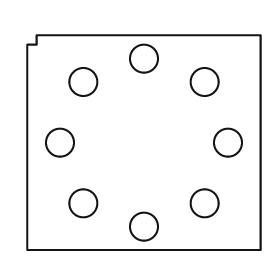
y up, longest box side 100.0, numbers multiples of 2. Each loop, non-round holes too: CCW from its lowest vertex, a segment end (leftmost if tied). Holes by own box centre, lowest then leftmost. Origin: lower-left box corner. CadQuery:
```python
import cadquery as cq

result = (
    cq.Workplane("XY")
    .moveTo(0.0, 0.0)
    .lineTo(100.0, 0.0)
    .lineTo(100.0, 92.0)
    .lineTo(4.0, 92.0)
    .lineTo(4.0, 88.0)
    .lineTo(0.0, 88.0)
    .close()
    .moveTo(50.0, 10.0)
    .circle(6.0)
    .moveTo(24.0, 20.0)
    .circle(6.0)
    .moveTo(76.0, 20.0)
    .circle(6.0)
    .moveTo(14.0, 46.0)
    .circle(6.0)
    .moveTo(86.0, 46.0)
    .circle(6.0)
    .moveTo(24.0, 72.0)
    .circle(6.0)
    .moveTo(76.0, 72.0)
    .circle(6.0)
    .moveTo(50.0, 82.0)
    .circle(6.0)
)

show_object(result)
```